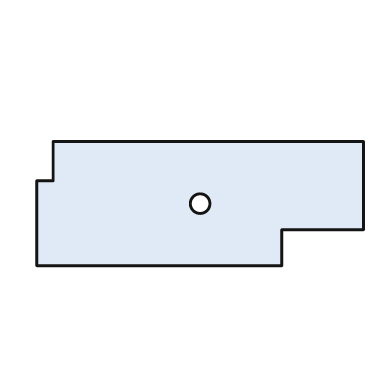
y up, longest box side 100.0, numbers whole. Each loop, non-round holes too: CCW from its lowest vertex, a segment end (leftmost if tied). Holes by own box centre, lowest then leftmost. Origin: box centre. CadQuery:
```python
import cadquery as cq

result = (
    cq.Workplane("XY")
    .moveTo(-50.0, -19.0)
    .lineTo(25.0, -19.0)
    .lineTo(25.0, -8.0)
    .lineTo(50.0, -8.0)
    .lineTo(50.0, 19.0)
    .lineTo(-45.0, 19.0)
    .lineTo(-45.0, 7.0)
    .lineTo(-50.0, 7.0)
    .close()
    .moveTo(0.0, 0.0)
    .circle(3.0)
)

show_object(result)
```